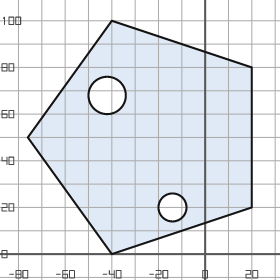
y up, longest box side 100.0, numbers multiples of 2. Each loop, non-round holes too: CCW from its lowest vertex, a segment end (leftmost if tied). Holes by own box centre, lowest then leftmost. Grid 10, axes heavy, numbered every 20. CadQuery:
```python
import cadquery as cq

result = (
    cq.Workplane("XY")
    .moveTo(-40.0, 0.0)
    .lineTo(20.0, 20.0)
    .lineTo(20.0, 80.0)
    .lineTo(-40.0, 100.0)
    .lineTo(-76.0, 50.0)
    .close()
    .moveTo(-14.0, 20.0)
    .circle(6.0)
    .moveTo(-42.0, 68.0)
    .circle(8.0)
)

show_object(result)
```